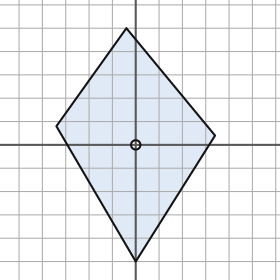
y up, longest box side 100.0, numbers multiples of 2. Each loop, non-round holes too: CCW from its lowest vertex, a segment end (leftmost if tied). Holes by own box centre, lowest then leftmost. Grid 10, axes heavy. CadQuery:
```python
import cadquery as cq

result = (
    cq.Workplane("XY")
    .moveTo(0.0, -50.0)
    .lineTo(34.0, 4.0)
    .lineTo(-4.0, 50.0)
    .lineTo(-34.0, 8.0)
    .close()
    .moveTo(0.0, 0.0)
    .circle(2.0)
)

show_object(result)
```